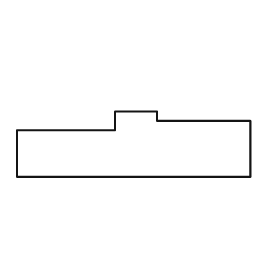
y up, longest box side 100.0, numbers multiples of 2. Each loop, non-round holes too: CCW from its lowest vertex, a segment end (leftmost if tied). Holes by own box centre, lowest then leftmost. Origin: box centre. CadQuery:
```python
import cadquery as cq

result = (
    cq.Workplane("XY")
    .moveTo(-50.0, -14.0)
    .lineTo(50.0, -14.0)
    .lineTo(50.0, 10.0)
    .lineTo(10.0, 10.0)
    .lineTo(10.0, 14.0)
    .lineTo(-8.0, 14.0)
    .lineTo(-8.0, 6.0)
    .lineTo(-50.0, 6.0)
    .close()
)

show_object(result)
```